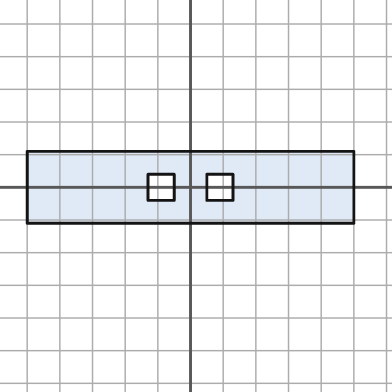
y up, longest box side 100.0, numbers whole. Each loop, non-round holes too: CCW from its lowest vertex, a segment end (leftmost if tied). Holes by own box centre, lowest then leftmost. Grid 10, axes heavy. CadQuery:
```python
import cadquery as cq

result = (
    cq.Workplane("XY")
    .moveTo(-50.0, -11.0)
    .lineTo(50.0, -11.0)
    .lineTo(50.0, 11.0)
    .lineTo(-50.0, 11.0)
    .close()
    .moveTo(-13.0, -4.0)
    .lineTo(-5.0, -4.0)
    .lineTo(-5.0, 4.0)
    .lineTo(-13.0, 4.0)
    .close()
    .moveTo(5.0, -4.0)
    .lineTo(13.0, -4.0)
    .lineTo(13.0, 4.0)
    .lineTo(5.0, 4.0)
    .close()
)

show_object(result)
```